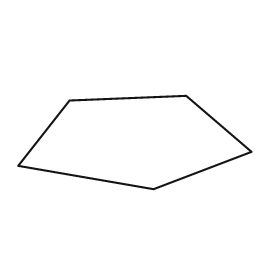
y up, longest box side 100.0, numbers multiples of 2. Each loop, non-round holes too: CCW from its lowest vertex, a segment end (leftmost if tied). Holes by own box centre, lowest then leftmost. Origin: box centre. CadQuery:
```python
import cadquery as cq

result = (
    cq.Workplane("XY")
    .moveTo(8.0, -20.0)
    .lineTo(50.0, -4.0)
    .lineTo(22.0, 20.0)
    .lineTo(-28.0, 18.0)
    .lineTo(-50.0, -10.0)
    .close()
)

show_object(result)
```